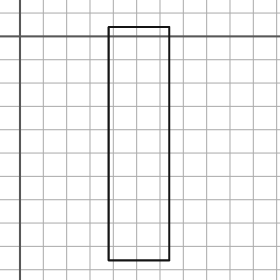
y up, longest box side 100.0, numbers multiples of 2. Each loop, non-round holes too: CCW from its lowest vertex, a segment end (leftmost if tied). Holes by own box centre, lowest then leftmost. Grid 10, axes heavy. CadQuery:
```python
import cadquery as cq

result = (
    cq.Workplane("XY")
    .moveTo(38.0, -96.0)
    .lineTo(64.0, -96.0)
    .lineTo(64.0, 4.0)
    .lineTo(38.0, 4.0)
    .close()
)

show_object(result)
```